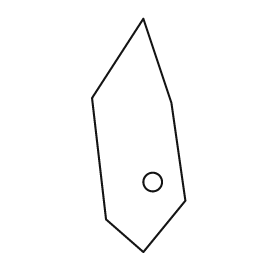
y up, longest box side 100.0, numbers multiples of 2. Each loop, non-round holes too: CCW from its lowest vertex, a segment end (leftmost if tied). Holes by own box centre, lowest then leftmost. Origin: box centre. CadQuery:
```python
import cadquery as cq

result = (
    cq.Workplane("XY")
    .moveTo(2.0, -50.0)
    .lineTo(20.0, -28.0)
    .lineTo(14.0, 14.0)
    .lineTo(2.0, 50.0)
    .lineTo(-20.0, 16.0)
    .lineTo(-14.0, -36.0)
    .close()
    .moveTo(6.0, -20.0)
    .circle(4.0)
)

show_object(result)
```